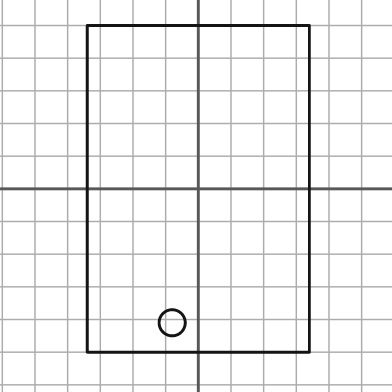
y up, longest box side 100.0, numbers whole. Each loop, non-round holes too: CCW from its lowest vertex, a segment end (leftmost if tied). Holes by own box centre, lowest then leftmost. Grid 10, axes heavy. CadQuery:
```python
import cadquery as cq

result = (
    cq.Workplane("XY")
    .moveTo(-34.0, -50.0)
    .lineTo(34.0, -50.0)
    .lineTo(34.0, 50.0)
    .lineTo(-34.0, 50.0)
    .close()
    .moveTo(-8.0, -41.0)
    .circle(4.0)
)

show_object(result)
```